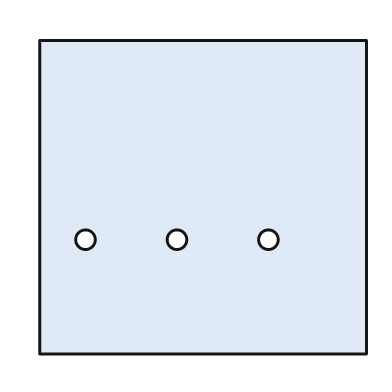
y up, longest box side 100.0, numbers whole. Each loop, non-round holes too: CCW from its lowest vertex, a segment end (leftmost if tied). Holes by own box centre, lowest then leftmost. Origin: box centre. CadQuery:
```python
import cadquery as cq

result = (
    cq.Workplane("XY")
    .moveTo(-50.0, -48.0)
    .lineTo(50.0, -48.0)
    .lineTo(50.0, 48.0)
    .lineTo(-50.0, 48.0)
    .close()
    .moveTo(-36.0, -13.0)
    .circle(3.0)
    .moveTo(-8.0, -13.0)
    .circle(3.0)
    .moveTo(20.0, -13.0)
    .circle(3.0)
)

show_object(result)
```